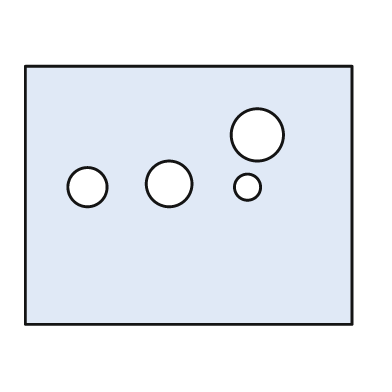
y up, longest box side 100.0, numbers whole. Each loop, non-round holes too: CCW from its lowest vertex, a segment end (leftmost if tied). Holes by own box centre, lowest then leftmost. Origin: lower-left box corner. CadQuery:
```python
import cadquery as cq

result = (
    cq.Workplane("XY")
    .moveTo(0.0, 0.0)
    .lineTo(100.0, 0.0)
    .lineTo(100.0, 79.0)
    .lineTo(0.0, 79.0)
    .close()
    .moveTo(19.0, 42.0)
    .circle(6.0)
    .moveTo(68.0, 42.0)
    .circle(4.0)
    .moveTo(44.0, 43.0)
    .circle(7.0)
    .moveTo(71.0, 58.0)
    .circle(8.0)
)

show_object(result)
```